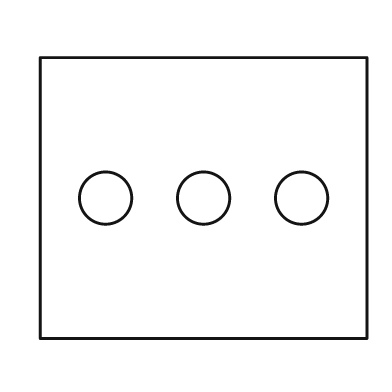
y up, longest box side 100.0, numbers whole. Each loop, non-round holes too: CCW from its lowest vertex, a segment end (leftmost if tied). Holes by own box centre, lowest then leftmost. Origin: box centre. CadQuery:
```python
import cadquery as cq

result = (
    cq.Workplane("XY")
    .moveTo(-50.0, -43.0)
    .lineTo(50.0, -43.0)
    .lineTo(50.0, 43.0)
    .lineTo(-50.0, 43.0)
    .close()
    .moveTo(-30.0, 0.0)
    .circle(8.0)
    .moveTo(0.0, 0.0)
    .circle(8.0)
    .moveTo(30.0, 0.0)
    .circle(8.0)
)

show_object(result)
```